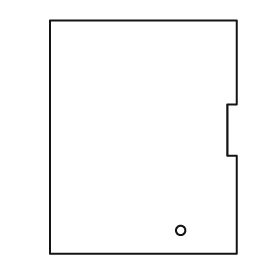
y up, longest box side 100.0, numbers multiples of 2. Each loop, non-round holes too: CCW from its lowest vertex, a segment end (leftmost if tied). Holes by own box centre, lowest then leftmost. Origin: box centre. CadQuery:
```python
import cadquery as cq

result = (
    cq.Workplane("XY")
    .moveTo(-40.0, -50.0)
    .lineTo(40.0, -50.0)
    .lineTo(40.0, -8.0)
    .lineTo(36.0, -8.0)
    .lineTo(36.0, 14.0)
    .lineTo(40.0, 14.0)
    .lineTo(40.0, 50.0)
    .lineTo(-40.0, 50.0)
    .close()
    .moveTo(16.0, -40.0)
    .circle(2.0)
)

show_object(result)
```